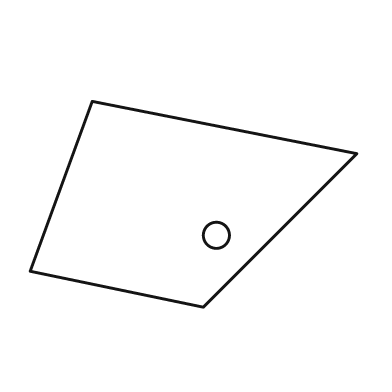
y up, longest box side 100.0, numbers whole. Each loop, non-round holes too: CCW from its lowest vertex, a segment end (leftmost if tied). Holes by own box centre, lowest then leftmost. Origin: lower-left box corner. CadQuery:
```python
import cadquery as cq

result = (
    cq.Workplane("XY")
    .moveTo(53.0, 0.0)
    .lineTo(100.0, 47.0)
    .lineTo(19.0, 63.0)
    .lineTo(0.0, 11.0)
    .close()
    .moveTo(57.0, 22.0)
    .circle(4.0)
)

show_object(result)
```